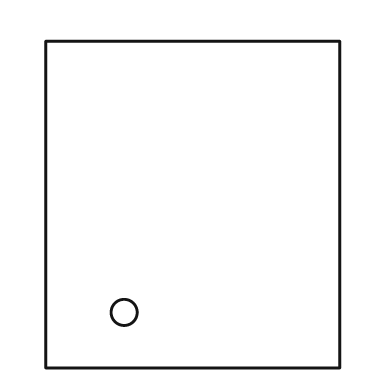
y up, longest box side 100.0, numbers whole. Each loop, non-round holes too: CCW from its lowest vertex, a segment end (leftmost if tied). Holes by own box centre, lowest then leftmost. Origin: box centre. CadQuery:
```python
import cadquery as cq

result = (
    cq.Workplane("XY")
    .moveTo(-45.0, -50.0)
    .lineTo(45.0, -50.0)
    .lineTo(45.0, 50.0)
    .lineTo(-45.0, 50.0)
    .close()
    .moveTo(-21.0, -33.0)
    .circle(4.0)
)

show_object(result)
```